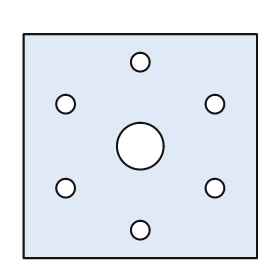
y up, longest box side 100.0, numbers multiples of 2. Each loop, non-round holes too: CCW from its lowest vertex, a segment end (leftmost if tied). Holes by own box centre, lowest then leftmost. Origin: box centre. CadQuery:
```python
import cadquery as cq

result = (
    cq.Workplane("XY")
    .moveTo(-50.0, -48.0)
    .lineTo(50.0, -48.0)
    .lineTo(50.0, 48.0)
    .lineTo(-50.0, 48.0)
    .close()
    .moveTo(0.0, -36.0)
    .circle(4.0)
    .moveTo(-32.0, -18.0)
    .circle(4.0)
    .moveTo(32.0, -18.0)
    .circle(4.0)
    .moveTo(0.0, 0.0)
    .circle(10.0)
    .moveTo(-32.0, 18.0)
    .circle(4.0)
    .moveTo(32.0, 18.0)
    .circle(4.0)
    .moveTo(0.0, 36.0)
    .circle(4.0)
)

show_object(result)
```